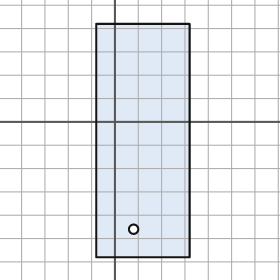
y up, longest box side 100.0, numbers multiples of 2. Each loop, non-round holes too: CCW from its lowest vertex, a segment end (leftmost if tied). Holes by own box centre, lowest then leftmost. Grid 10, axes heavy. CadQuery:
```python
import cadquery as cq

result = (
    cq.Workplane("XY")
    .moveTo(-8.0, -58.0)
    .lineTo(32.0, -58.0)
    .lineTo(32.0, 42.0)
    .lineTo(-8.0, 42.0)
    .close()
    .moveTo(8.0, -46.0)
    .circle(2.0)
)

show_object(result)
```